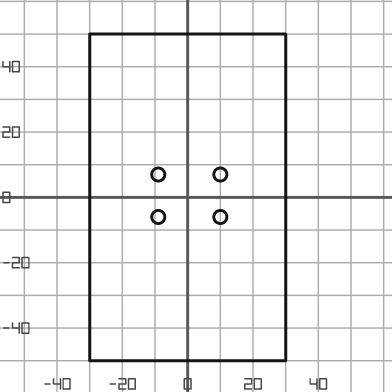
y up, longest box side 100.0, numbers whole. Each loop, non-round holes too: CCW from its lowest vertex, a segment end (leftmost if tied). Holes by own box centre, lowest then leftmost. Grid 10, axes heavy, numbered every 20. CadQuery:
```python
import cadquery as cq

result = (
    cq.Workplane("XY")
    .moveTo(-30.0, -50.0)
    .lineTo(30.0, -50.0)
    .lineTo(30.0, 50.0)
    .lineTo(-30.0, 50.0)
    .close()
    .moveTo(-9.0, -6.0)
    .circle(2.0)
    .moveTo(10.0, -6.0)
    .circle(2.0)
    .moveTo(-9.0, 7.0)
    .circle(2.0)
    .moveTo(10.0, 7.0)
    .circle(2.0)
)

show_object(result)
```